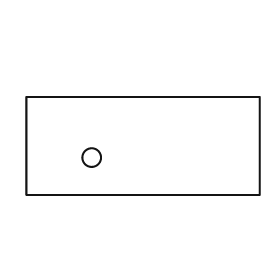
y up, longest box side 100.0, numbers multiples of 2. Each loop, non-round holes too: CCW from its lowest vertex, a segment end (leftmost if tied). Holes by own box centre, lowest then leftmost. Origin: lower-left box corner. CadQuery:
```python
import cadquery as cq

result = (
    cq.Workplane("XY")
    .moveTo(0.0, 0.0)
    .lineTo(100.0, 0.0)
    .lineTo(100.0, 42.0)
    .lineTo(0.0, 42.0)
    .close()
    .moveTo(28.0, 16.0)
    .circle(4.0)
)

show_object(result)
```